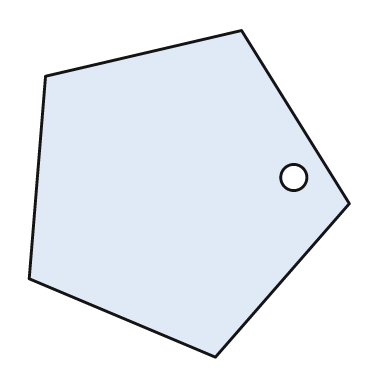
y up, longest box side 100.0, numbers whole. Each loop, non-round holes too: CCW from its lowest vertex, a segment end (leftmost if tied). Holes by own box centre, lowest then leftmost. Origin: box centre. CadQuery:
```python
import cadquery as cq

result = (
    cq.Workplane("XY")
    .moveTo(8.0, -50.0)
    .lineTo(49.0, -3.0)
    .lineTo(16.0, 50.0)
    .lineTo(-44.0, 36.0)
    .lineTo(-49.0, -26.0)
    .close()
    .moveTo(32.0, 5.0)
    .circle(4.0)
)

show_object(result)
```